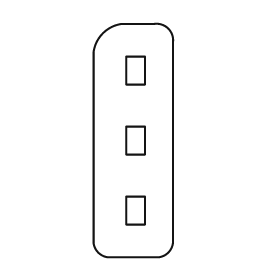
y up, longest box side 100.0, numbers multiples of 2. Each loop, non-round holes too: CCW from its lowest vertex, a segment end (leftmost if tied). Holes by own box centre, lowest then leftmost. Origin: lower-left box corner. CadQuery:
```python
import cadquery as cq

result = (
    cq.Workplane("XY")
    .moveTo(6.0, 0.0)
    .lineTo(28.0, 0.0)
    .threePointArc((32.0, 2.0), (34.0, 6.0))
    .lineTo(34.0, 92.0)
    .threePointArc((32.0, 98.0), (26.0, 100.0))
    .lineTo(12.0, 100.0)
    .threePointArc((4.0, 96.0), (0.0, 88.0))
    .lineTo(0.0, 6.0)
    .threePointArc((2.0, 2.0), (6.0, 0.0))
    .close()
    .moveTo(14.0, 14.0)
    .lineTo(22.0, 14.0)
    .lineTo(22.0, 26.0)
    .lineTo(14.0, 26.0)
    .close()
    .moveTo(14.0, 44.0)
    .lineTo(22.0, 44.0)
    .lineTo(22.0, 56.0)
    .lineTo(14.0, 56.0)
    .close()
    .moveTo(14.0, 74.0)
    .lineTo(22.0, 74.0)
    .lineTo(22.0, 86.0)
    .lineTo(14.0, 86.0)
    .close()
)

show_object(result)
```